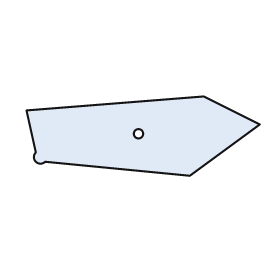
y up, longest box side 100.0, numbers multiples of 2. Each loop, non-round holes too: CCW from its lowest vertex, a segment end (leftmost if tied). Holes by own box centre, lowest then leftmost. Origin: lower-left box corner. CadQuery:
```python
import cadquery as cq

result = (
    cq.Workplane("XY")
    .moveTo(70.0, 0.0)
    .lineTo(100.0, 22.0)
    .lineTo(76.0, 34.0)
    .lineTo(0.0, 28.0)
    .lineTo(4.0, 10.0)
    .threePointArc((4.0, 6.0), (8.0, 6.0))
    .close()
    .moveTo(48.0, 18.0)
    .circle(2.0)
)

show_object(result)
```